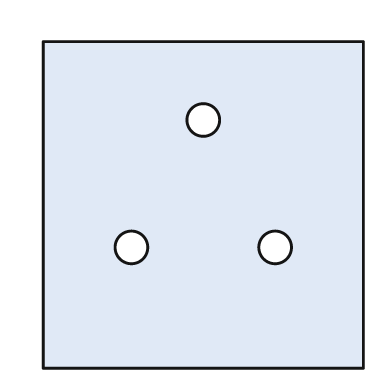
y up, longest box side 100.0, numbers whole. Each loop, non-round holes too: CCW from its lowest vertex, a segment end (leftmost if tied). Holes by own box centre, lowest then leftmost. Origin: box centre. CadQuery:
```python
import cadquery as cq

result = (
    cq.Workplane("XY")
    .moveTo(-49.0, -50.0)
    .lineTo(49.0, -50.0)
    .lineTo(49.0, 50.0)
    .lineTo(-49.0, 50.0)
    .close()
    .moveTo(-22.0, -13.0)
    .circle(5.0)
    .moveTo(22.0, -13.0)
    .circle(5.0)
    .moveTo(0.0, 26.0)
    .circle(5.0)
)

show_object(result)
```